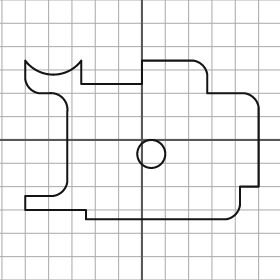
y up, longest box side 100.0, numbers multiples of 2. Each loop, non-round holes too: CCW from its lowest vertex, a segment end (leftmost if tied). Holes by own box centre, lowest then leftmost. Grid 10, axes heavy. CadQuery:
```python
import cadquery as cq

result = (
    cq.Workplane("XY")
    .moveTo(-24.0, -34.0)
    .lineTo(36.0, -34.0)
    .threePointArc((40.0, -32.0), (42.0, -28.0))
    .lineTo(42.0, -20.0)
    .lineTo(50.0, -20.0)
    .lineTo(50.0, 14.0)
    .threePointArc((48.0, 18.0), (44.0, 20.0))
    .lineTo(28.0, 20.0)
    .lineTo(28.0, 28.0)
    .threePointArc((26.0, 32.0), (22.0, 34.0))
    .lineTo(0.0, 34.0)
    .lineTo(0.0, 24.0)
    .lineTo(-26.0, 24.0)
    .lineTo(-26.0, 34.0)
    .threePointArc((-38.0, 28.0), (-50.0, 34.0))
    .lineTo(-50.0, 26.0)
    .threePointArc((-48.0, 22.0), (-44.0, 20.0))
    .lineTo(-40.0, 20.0)
    .threePointArc((-34.0, 18.0), (-32.0, 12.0))
    .lineTo(-32.0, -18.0)
    .threePointArc((-34.0, -22.0), (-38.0, -24.0))
    .lineTo(-50.0, -24.0)
    .lineTo(-50.0, -30.0)
    .lineTo(-24.0, -30.0)
    .close()
    .moveTo(4.0, -6.0)
    .circle(6.0)
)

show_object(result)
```